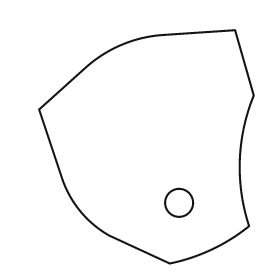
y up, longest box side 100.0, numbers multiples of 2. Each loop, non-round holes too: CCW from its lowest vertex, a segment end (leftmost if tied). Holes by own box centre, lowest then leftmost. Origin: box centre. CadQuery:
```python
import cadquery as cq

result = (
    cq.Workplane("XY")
    .moveTo(10.0, -50.0)
    .threePointArc((28.0, -44.0), (44.0, -34.0))
    .threePointArc((40.0, -6.0), (46.0, 22.0))
    .lineTo(38.0, 50.0)
    .lineTo(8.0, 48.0)
    .threePointArc((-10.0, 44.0), (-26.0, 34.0))
    .lineTo(-46.0, 16.0)
    .lineTo(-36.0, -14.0)
    .threePointArc((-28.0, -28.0), (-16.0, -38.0))
    .close()
    .moveTo(14.0, -24.0)
    .circle(6.0)
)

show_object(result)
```